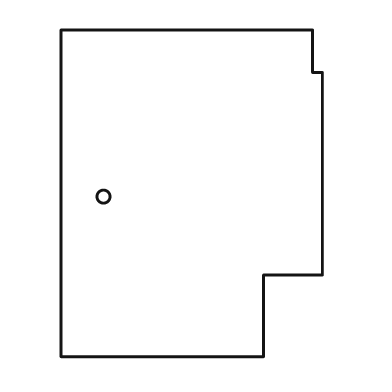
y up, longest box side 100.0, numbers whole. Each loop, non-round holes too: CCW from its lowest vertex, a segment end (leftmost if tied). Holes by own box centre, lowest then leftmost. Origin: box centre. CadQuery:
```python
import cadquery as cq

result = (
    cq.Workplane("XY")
    .moveTo(-40.0, -50.0)
    .lineTo(22.0, -50.0)
    .lineTo(22.0, -25.0)
    .lineTo(40.0, -25.0)
    .lineTo(40.0, 37.0)
    .lineTo(37.0, 37.0)
    .lineTo(37.0, 50.0)
    .lineTo(-40.0, 50.0)
    .close()
    .moveTo(-27.0, -1.0)
    .circle(2.0)
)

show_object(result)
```